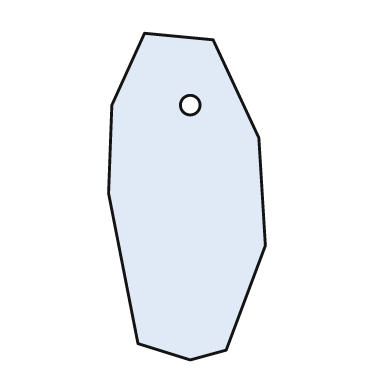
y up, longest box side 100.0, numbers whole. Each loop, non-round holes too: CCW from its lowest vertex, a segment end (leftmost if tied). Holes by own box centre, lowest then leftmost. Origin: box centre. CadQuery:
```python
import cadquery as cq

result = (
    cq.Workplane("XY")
    .moveTo(1.0, -50.0)
    .lineTo(12.0, -47.0)
    .lineTo(24.0, -15.0)
    .lineTo(22.0, 18.0)
    .lineTo(8.0, 48.0)
    .lineTo(-13.0, 50.0)
    .lineTo(-23.0, 28.0)
    .lineTo(-24.0, 1.0)
    .lineTo(-15.0, -45.0)
    .close()
    .moveTo(1.0, 28.0)
    .circle(3.0)
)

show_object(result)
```